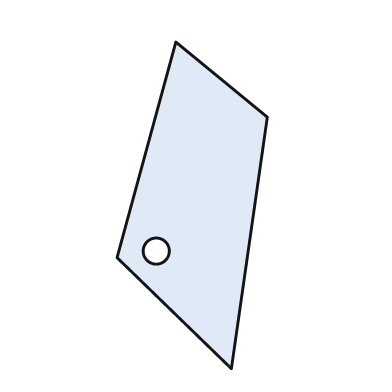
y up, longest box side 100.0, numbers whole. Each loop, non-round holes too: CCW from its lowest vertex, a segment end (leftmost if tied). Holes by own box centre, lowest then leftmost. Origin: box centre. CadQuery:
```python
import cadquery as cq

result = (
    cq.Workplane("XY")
    .moveTo(12.0, -50.0)
    .lineTo(23.0, 27.0)
    .lineTo(-5.0, 50.0)
    .lineTo(-23.0, -16.0)
    .close()
    .moveTo(-11.0, -14.0)
    .circle(4.0)
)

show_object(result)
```